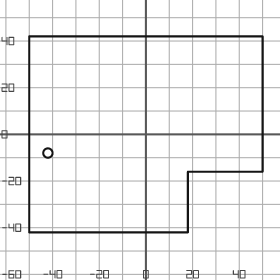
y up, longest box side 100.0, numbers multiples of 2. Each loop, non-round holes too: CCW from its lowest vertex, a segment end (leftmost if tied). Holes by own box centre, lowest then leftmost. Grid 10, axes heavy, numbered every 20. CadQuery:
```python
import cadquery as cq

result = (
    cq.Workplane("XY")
    .moveTo(-50.0, -42.0)
    .lineTo(18.0, -42.0)
    .lineTo(18.0, -16.0)
    .lineTo(50.0, -16.0)
    .lineTo(50.0, 42.0)
    .lineTo(-50.0, 42.0)
    .close()
    .moveTo(-42.0, -8.0)
    .circle(2.0)
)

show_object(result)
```